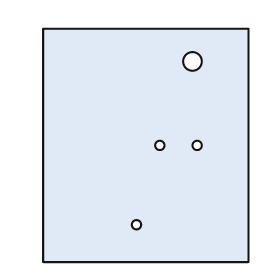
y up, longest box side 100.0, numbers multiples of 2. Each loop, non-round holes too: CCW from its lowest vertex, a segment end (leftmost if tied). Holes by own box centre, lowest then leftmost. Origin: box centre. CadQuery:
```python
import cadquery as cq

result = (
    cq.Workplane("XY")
    .moveTo(-44.0, -50.0)
    .lineTo(44.0, -50.0)
    .lineTo(44.0, 50.0)
    .lineTo(-44.0, 50.0)
    .close()
    .moveTo(-4.0, -34.0)
    .circle(2.0)
    .moveTo(6.0, 0.0)
    .circle(2.0)
    .moveTo(22.0, 0.0)
    .circle(2.0)
    .moveTo(20.0, 36.0)
    .circle(4.0)
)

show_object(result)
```